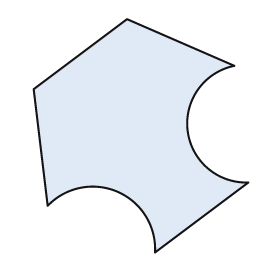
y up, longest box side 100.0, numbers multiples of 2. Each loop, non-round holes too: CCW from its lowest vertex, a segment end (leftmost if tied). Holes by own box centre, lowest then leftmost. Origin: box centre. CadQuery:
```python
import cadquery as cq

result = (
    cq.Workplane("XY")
    .moveTo(6.0, -50.0)
    .lineTo(46.0, -20.0)
    .threePointArc((20.0, 2.0), (40.0, 30.0))
    .lineTo(-6.0, 50.0)
    .lineTo(-46.0, 20.0)
    .lineTo(-40.0, -30.0)
    .threePointArc((-10.0, -24.0), (6.0, -50.0))
    .close()
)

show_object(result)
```